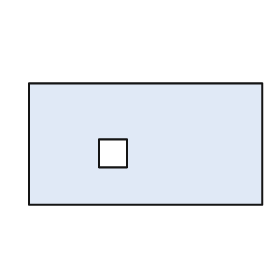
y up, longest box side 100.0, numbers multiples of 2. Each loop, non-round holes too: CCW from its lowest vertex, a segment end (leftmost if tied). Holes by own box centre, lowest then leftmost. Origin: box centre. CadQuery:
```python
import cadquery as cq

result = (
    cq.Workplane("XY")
    .moveTo(-50.0, -26.0)
    .lineTo(50.0, -26.0)
    .lineTo(50.0, 26.0)
    .lineTo(-50.0, 26.0)
    .close()
    .moveTo(-20.0, -10.0)
    .lineTo(-8.0, -10.0)
    .lineTo(-8.0, 2.0)
    .lineTo(-20.0, 2.0)
    .close()
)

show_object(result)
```